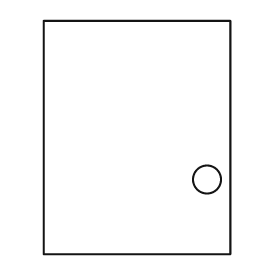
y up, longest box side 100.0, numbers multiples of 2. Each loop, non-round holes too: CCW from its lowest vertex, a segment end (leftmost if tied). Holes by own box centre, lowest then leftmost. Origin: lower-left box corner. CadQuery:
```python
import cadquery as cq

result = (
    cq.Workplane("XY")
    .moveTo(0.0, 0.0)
    .lineTo(80.0, 0.0)
    .lineTo(80.0, 100.0)
    .lineTo(0.0, 100.0)
    .close()
    .moveTo(70.0, 32.0)
    .circle(6.0)
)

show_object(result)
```